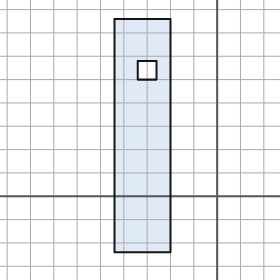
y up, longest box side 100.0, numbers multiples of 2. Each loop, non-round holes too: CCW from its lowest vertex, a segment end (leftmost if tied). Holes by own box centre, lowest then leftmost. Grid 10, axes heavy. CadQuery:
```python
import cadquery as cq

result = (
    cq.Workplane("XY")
    .moveTo(-44.0, -24.0)
    .lineTo(-20.0, -24.0)
    .lineTo(-20.0, 76.0)
    .lineTo(-44.0, 76.0)
    .close()
    .moveTo(-34.0, 50.0)
    .lineTo(-26.0, 50.0)
    .lineTo(-26.0, 58.0)
    .lineTo(-34.0, 58.0)
    .close()
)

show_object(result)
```